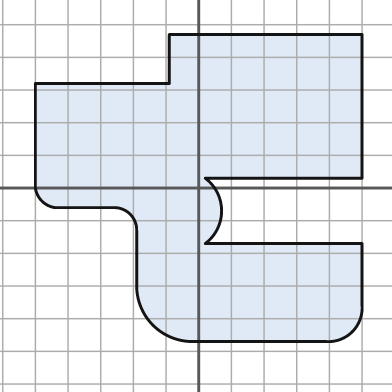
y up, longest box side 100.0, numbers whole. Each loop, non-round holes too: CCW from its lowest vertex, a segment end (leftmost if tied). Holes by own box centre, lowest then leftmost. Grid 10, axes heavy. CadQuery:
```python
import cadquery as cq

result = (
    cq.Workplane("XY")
    .moveTo(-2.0, -47.0)
    .lineTo(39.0, -47.0)
    .threePointArc((47.0, -44.0), (50.0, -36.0))
    .lineTo(50.0, -17.0)
    .lineTo(2.0, -17.0)
    .threePointArc((7.0, -7.0), (2.0, 3.0))
    .lineTo(50.0, 3.0)
    .lineTo(50.0, 47.0)
    .lineTo(-9.0, 47.0)
    .lineTo(-9.0, 32.0)
    .lineTo(-50.0, 32.0)
    .lineTo(-50.0, 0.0)
    .threePointArc((-48.0, -4.0), (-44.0, -6.0))
    .lineTo(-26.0, -6.0)
    .threePointArc((-21.0, -8.0), (-19.0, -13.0))
    .lineTo(-19.0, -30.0)
    .threePointArc((-14.0, -42.0), (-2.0, -47.0))
    .close()
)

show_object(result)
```